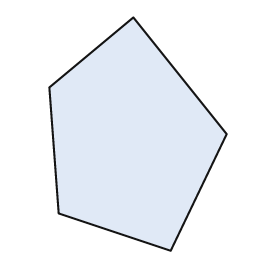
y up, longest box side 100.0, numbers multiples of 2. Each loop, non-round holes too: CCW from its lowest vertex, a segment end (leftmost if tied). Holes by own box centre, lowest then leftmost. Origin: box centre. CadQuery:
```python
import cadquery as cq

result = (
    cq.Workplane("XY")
    .moveTo(14.0, -50.0)
    .lineTo(38.0, 0.0)
    .lineTo(-2.0, 50.0)
    .lineTo(-38.0, 20.0)
    .lineTo(-34.0, -34.0)
    .close()
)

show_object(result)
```